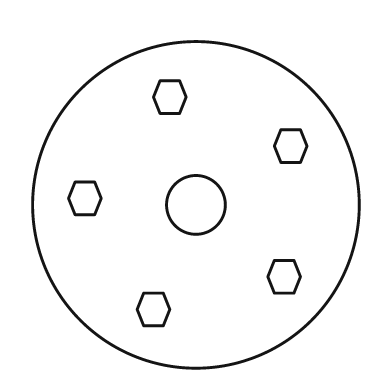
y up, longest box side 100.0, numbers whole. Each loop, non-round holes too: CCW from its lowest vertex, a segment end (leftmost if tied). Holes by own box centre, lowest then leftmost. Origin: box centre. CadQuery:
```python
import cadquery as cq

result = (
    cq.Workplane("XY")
    .moveTo(0.0, 0.0)
    .circle(50.0)
    .moveTo(-16.0, -37.0)
    .lineTo(-10.0, -37.0)
    .lineTo(-8.0, -32.0)
    .lineTo(-10.0, -27.0)
    .lineTo(-16.0, -27.0)
    .lineTo(-18.0, -32.0)
    .close()
    .moveTo(24.0, -27.0)
    .lineTo(30.0, -27.0)
    .lineTo(32.0, -22.0)
    .lineTo(30.0, -17.0)
    .lineTo(24.0, -17.0)
    .lineTo(22.0, -22.0)
    .close()
    .moveTo(0.0, 0.0)
    .circle(9.0)
    .moveTo(-37.0, -3.0)
    .lineTo(-31.0, -3.0)
    .lineTo(-29.0, 2.0)
    .lineTo(-31.0, 7.0)
    .lineTo(-37.0, 7.0)
    .lineTo(-39.0, 2.0)
    .close()
    .moveTo(26.0, 13.0)
    .lineTo(32.0, 13.0)
    .lineTo(34.0, 18.0)
    .lineTo(32.0, 23.0)
    .lineTo(26.0, 23.0)
    .lineTo(24.0, 18.0)
    .close()
    .moveTo(-11.0, 28.0)
    .lineTo(-5.0, 28.0)
    .lineTo(-3.0, 33.0)
    .lineTo(-5.0, 38.0)
    .lineTo(-11.0, 38.0)
    .lineTo(-13.0, 33.0)
    .close()
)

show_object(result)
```